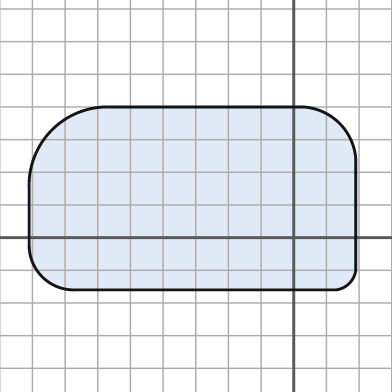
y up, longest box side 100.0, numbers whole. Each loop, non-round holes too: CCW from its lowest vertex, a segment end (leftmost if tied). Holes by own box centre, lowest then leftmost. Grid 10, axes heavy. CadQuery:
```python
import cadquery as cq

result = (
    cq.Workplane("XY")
    .moveTo(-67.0, -16.0)
    .lineTo(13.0, -16.0)
    .threePointArc((17.0, -14.0), (19.0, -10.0))
    .lineTo(19.0, 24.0)
    .threePointArc((14.0, 35.0), (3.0, 40.0))
    .lineTo(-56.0, 40.0)
    .threePointArc((-74.0, 33.0), (-81.0, 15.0))
    .lineTo(-81.0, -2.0)
    .threePointArc((-77.0, -12.0), (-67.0, -16.0))
    .close()
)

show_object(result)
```